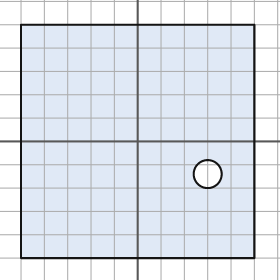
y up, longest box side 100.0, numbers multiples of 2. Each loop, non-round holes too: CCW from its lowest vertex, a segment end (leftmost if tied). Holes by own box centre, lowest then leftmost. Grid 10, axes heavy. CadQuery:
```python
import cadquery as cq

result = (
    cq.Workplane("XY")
    .moveTo(-50.0, -50.0)
    .lineTo(50.0, -50.0)
    .lineTo(50.0, 50.0)
    .lineTo(-50.0, 50.0)
    .close()
    .moveTo(30.0, -14.0)
    .circle(6.0)
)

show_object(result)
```